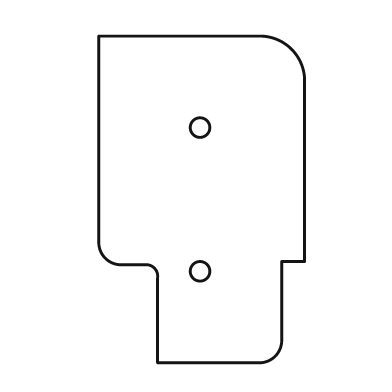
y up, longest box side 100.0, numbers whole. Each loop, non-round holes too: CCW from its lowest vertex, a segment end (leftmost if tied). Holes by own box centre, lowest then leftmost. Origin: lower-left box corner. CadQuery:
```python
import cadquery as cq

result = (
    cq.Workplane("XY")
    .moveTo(18.0, 0.0)
    .lineTo(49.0, 0.0)
    .threePointArc((54.0, 2.0), (56.0, 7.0))
    .lineTo(56.0, 31.0)
    .lineTo(63.0, 31.0)
    .lineTo(63.0, 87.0)
    .threePointArc((59.0, 96.0), (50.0, 100.0))
    .lineTo(0.0, 100.0)
    .lineTo(0.0, 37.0)
    .threePointArc((2.0, 32.0), (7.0, 30.0))
    .lineTo(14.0, 30.0)
    .threePointArc((17.0, 29.0), (18.0, 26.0))
    .close()
    .moveTo(31.0, 28.0)
    .circle(3.0)
    .moveTo(31.0, 72.0)
    .circle(3.0)
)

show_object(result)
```